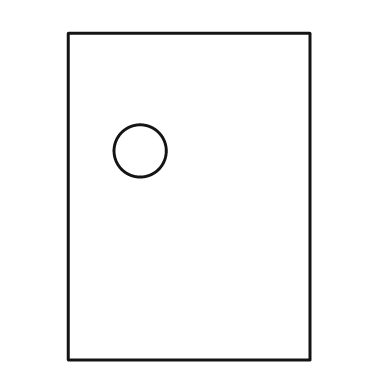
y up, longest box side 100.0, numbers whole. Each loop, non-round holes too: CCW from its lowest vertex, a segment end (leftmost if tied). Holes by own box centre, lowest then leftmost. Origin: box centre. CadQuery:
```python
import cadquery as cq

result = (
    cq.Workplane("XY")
    .moveTo(-37.0, -50.0)
    .lineTo(37.0, -50.0)
    .lineTo(37.0, 50.0)
    .lineTo(-37.0, 50.0)
    .close()
    .moveTo(-15.0, 14.0)
    .circle(8.0)
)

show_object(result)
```